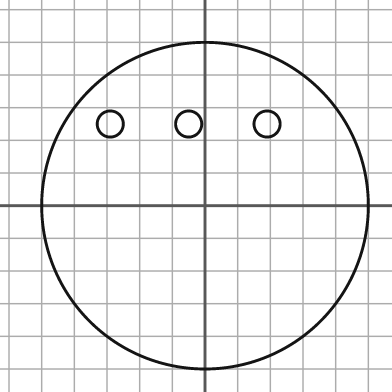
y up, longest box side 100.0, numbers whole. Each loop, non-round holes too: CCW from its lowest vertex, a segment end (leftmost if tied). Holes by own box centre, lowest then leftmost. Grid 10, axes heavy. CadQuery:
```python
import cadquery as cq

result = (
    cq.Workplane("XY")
    .moveTo(0.0, 0.0)
    .circle(50.0)
    .moveTo(-29.0, 25.0)
    .circle(4.0)
    .moveTo(-5.0, 25.0)
    .circle(4.0)
    .moveTo(19.0, 25.0)
    .circle(4.0)
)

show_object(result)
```